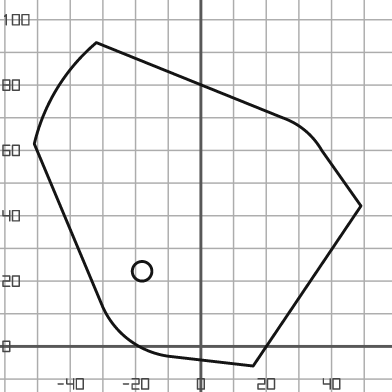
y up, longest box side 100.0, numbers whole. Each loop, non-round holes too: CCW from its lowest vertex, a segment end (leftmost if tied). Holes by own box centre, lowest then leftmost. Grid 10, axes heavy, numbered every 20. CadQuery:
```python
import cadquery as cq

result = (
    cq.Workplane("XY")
    .moveTo(16.0, -6.0)
    .lineTo(49.0, 43.0)
    .lineTo(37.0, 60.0)
    .threePointArc((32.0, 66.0), (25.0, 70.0))
    .lineTo(-32.0, 93.0)
    .threePointArc((-44.0, 79.0), (-51.0, 62.0))
    .lineTo(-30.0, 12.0)
    .threePointArc((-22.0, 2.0), (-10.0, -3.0))
    .close()
    .moveTo(-18.0, 23.0)
    .circle(3.0)
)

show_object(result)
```